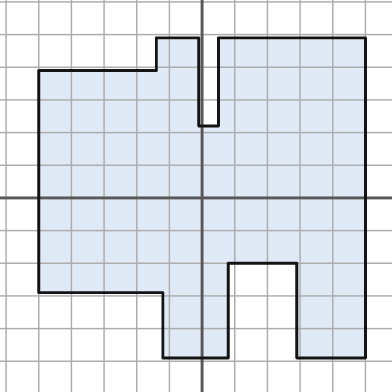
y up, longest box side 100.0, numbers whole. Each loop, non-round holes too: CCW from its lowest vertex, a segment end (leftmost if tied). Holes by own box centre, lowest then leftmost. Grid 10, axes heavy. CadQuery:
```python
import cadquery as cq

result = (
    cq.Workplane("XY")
    .moveTo(-12.0, -49.0)
    .lineTo(8.0, -49.0)
    .lineTo(8.0, -20.0)
    .lineTo(29.0, -20.0)
    .lineTo(29.0, -49.0)
    .lineTo(50.0, -49.0)
    .lineTo(50.0, 49.0)
    .lineTo(5.0, 49.0)
    .lineTo(5.0, 22.0)
    .lineTo(-1.0, 22.0)
    .lineTo(-1.0, 49.0)
    .lineTo(-14.0, 49.0)
    .lineTo(-14.0, 39.0)
    .lineTo(-50.0, 39.0)
    .lineTo(-50.0, -29.0)
    .lineTo(-12.0, -29.0)
    .close()
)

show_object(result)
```